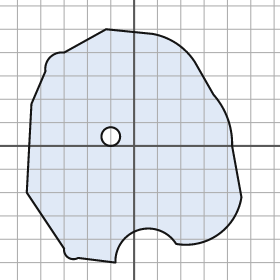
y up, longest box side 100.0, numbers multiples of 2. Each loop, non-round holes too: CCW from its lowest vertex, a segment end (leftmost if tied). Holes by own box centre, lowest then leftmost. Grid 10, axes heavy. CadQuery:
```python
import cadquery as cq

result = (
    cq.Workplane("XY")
    .moveTo(-8.0, -50.0)
    .threePointArc((2.0, -36.0), (18.0, -42.0))
    .threePointArc((36.0, -38.0), (46.0, -22.0))
    .lineTo(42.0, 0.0)
    .threePointArc((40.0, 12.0), (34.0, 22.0))
    .lineTo(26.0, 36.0)
    .threePointArc((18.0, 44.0), (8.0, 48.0))
    .lineTo(-12.0, 50.0)
    .lineTo(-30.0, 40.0)
    .threePointArc((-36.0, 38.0), (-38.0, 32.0))
    .lineTo(-44.0, 18.0)
    .lineTo(-46.0, -20.0)
    .lineTo(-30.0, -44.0)
    .threePointArc((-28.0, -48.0), (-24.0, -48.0))
    .close()
    .moveTo(-10.0, 4.0)
    .circle(4.0)
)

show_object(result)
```